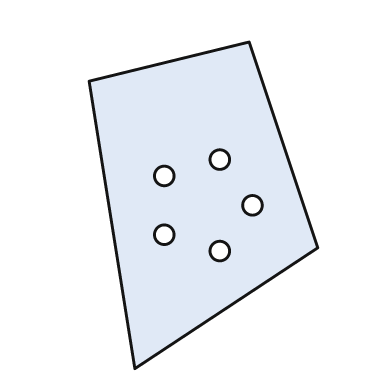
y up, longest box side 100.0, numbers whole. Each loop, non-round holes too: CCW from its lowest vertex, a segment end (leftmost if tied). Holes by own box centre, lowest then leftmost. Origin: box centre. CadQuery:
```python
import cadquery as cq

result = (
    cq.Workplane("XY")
    .moveTo(-21.0, -50.0)
    .lineTo(35.0, -13.0)
    .lineTo(14.0, 50.0)
    .lineTo(-35.0, 38.0)
    .close()
    .moveTo(5.0, -14.0)
    .circle(3.0)
    .moveTo(-12.0, -9.0)
    .circle(3.0)
    .moveTo(15.0, 0.0)
    .circle(3.0)
    .moveTo(-12.0, 9.0)
    .circle(3.0)
    .moveTo(5.0, 14.0)
    .circle(3.0)
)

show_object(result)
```